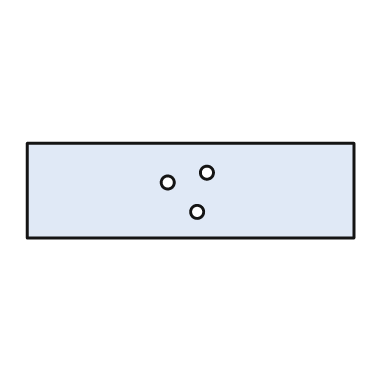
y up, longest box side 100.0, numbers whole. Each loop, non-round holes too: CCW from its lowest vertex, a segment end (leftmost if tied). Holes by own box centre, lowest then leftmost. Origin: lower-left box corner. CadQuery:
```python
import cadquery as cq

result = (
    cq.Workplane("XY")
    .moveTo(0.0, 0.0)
    .lineTo(100.0, 0.0)
    .lineTo(100.0, 29.0)
    .lineTo(0.0, 29.0)
    .close()
    .moveTo(52.0, 8.0)
    .circle(2.0)
    .moveTo(43.0, 17.0)
    .circle(2.0)
    .moveTo(55.0, 20.0)
    .circle(2.0)
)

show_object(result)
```